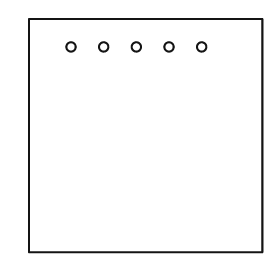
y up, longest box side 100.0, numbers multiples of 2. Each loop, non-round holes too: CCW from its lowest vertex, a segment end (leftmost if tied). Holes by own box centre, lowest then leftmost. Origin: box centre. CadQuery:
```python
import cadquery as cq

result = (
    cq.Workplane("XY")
    .moveTo(-50.0, -50.0)
    .lineTo(50.0, -50.0)
    .lineTo(50.0, 50.0)
    .lineTo(-50.0, 50.0)
    .close()
    .moveTo(-32.0, 38.0)
    .circle(2.0)
    .moveTo(-18.0, 38.0)
    .circle(2.0)
    .moveTo(-4.0, 38.0)
    .circle(2.0)
    .moveTo(10.0, 38.0)
    .circle(2.0)
    .moveTo(24.0, 38.0)
    .circle(2.0)
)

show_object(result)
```